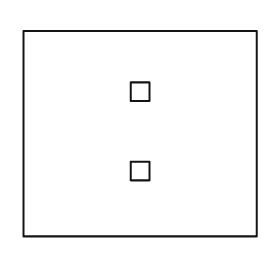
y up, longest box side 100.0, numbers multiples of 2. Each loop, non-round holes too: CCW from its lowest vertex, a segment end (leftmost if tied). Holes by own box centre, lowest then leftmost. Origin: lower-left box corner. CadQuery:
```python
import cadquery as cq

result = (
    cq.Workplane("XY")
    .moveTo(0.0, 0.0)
    .lineTo(100.0, 0.0)
    .lineTo(100.0, 88.0)
    .lineTo(0.0, 88.0)
    .close()
    .moveTo(46.0, 24.0)
    .lineTo(54.0, 24.0)
    .lineTo(54.0, 32.0)
    .lineTo(46.0, 32.0)
    .close()
    .moveTo(46.0, 58.0)
    .lineTo(54.0, 58.0)
    .lineTo(54.0, 66.0)
    .lineTo(46.0, 66.0)
    .close()
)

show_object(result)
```